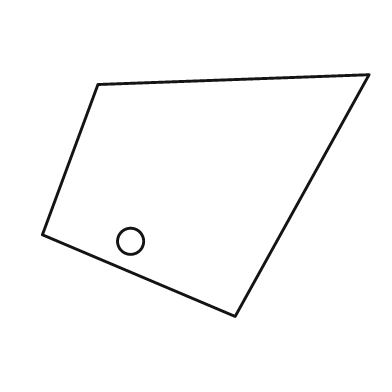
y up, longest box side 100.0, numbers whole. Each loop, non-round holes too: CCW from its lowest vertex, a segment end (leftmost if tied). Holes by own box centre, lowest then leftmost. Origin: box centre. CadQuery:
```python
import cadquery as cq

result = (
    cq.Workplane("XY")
    .moveTo(9.0, -37.0)
    .lineTo(50.0, 37.0)
    .lineTo(-33.0, 34.0)
    .lineTo(-50.0, -12.0)
    .close()
    .moveTo(-23.0, -14.0)
    .circle(4.0)
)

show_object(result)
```